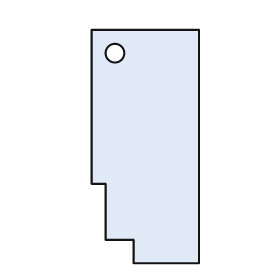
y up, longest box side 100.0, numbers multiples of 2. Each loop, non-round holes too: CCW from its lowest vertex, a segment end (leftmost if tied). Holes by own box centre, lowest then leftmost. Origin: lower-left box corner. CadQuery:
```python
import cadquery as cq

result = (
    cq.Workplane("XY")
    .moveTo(18.0, 0.0)
    .lineTo(46.0, 0.0)
    .lineTo(46.0, 100.0)
    .lineTo(0.0, 100.0)
    .lineTo(0.0, 34.0)
    .lineTo(6.0, 34.0)
    .lineTo(6.0, 10.0)
    .lineTo(18.0, 10.0)
    .close()
    .moveTo(10.0, 90.0)
    .circle(4.0)
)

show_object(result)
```